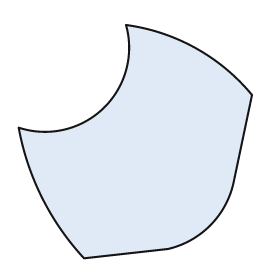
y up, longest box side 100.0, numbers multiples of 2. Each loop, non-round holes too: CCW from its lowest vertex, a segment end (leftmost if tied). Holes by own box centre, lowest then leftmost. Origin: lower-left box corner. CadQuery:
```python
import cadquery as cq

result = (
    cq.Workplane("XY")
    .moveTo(28.0, 0.0)
    .lineTo(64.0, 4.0)
    .threePointArc((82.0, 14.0), (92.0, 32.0))
    .lineTo(100.0, 70.0)
    .threePointArc((76.0, 90.0), (46.0, 100.0))
    .threePointArc((36.0, 64.0), (0.0, 56.0))
    .threePointArc((10.0, 26.0), (28.0, 0.0))
    .close()
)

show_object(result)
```